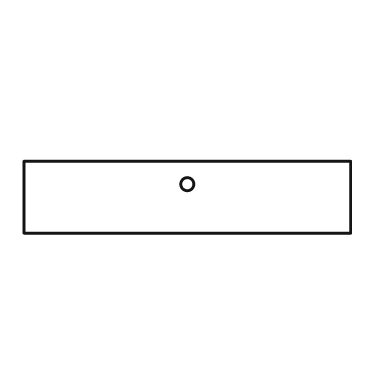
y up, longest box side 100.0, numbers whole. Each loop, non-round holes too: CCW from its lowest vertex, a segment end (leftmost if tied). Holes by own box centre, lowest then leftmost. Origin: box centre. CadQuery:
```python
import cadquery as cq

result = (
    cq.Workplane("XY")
    .moveTo(-50.0, -11.0)
    .lineTo(50.0, -11.0)
    .lineTo(50.0, 11.0)
    .lineTo(-50.0, 11.0)
    .close()
    .moveTo(0.0, 4.0)
    .circle(2.0)
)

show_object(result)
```